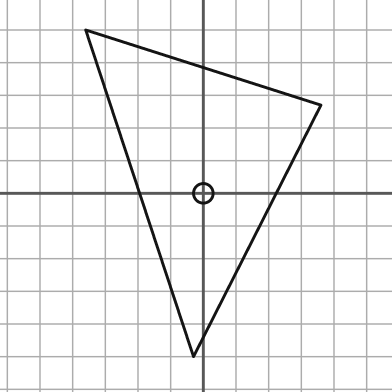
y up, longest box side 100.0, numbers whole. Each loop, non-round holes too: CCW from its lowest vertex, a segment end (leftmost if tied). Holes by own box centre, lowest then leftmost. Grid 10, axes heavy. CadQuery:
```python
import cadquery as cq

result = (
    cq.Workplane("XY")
    .moveTo(-3.0, -50.0)
    .lineTo(36.0, 27.0)
    .lineTo(-36.0, 50.0)
    .close()
    .moveTo(0.0, 0.0)
    .circle(3.0)
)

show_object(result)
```